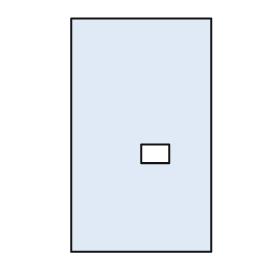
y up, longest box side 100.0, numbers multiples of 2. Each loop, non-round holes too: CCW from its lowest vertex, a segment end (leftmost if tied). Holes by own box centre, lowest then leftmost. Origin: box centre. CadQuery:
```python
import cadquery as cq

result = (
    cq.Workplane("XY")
    .moveTo(-30.0, -50.0)
    .lineTo(30.0, -50.0)
    .lineTo(30.0, 50.0)
    .lineTo(-30.0, 50.0)
    .close()
    .moveTo(0.0, -12.0)
    .lineTo(12.0, -12.0)
    .lineTo(12.0, -4.0)
    .lineTo(0.0, -4.0)
    .close()
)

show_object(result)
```